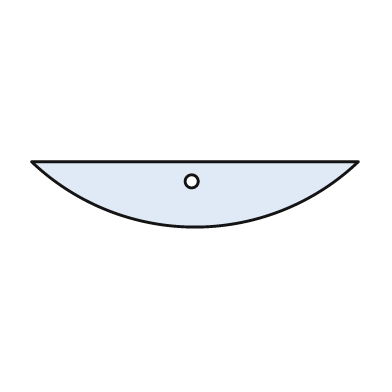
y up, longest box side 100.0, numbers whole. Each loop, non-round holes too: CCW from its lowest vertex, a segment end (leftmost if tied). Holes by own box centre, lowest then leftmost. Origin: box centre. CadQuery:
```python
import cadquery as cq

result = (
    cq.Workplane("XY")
    .moveTo(-50.0, 10.0)
    .threePointArc((0.0, -10.0), (50.0, 10.0))
    .close()
    .moveTo(-1.0, 4.0)
    .circle(2.0)
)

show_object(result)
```